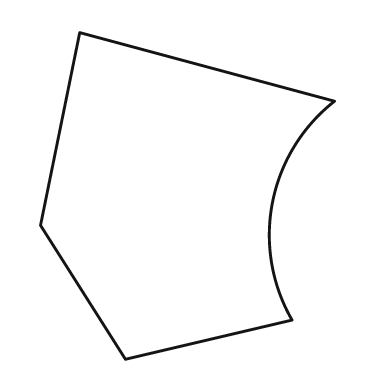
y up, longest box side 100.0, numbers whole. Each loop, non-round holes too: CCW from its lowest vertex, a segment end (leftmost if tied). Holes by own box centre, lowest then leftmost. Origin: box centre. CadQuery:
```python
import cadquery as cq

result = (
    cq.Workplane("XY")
    .moveTo(-19.0, -50.0)
    .lineTo(32.0, -38.0)
    .threePointArc((26.0, -2.0), (45.0, 29.0))
    .lineTo(-33.0, 50.0)
    .lineTo(-45.0, -9.0)
    .close()
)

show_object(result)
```